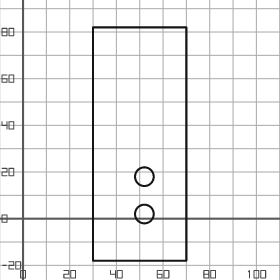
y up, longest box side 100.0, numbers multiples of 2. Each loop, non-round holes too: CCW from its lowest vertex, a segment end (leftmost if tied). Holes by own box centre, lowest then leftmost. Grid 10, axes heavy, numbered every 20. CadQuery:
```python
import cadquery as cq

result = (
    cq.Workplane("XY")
    .moveTo(30.0, -18.0)
    .lineTo(70.0, -18.0)
    .lineTo(70.0, 82.0)
    .lineTo(30.0, 82.0)
    .close()
    .moveTo(52.0, 2.0)
    .circle(4.0)
    .moveTo(52.0, 18.0)
    .circle(4.0)
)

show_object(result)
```